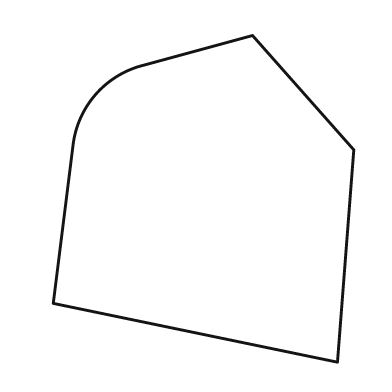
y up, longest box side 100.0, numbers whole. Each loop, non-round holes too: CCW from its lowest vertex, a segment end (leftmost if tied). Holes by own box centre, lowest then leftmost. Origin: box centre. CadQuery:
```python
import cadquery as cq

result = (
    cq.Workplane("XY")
    .moveTo(41.0, -50.0)
    .lineTo(46.0, 15.0)
    .lineTo(15.0, 50.0)
    .lineTo(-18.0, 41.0)
    .threePointArc((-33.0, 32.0), (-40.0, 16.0))
    .lineTo(-46.0, -32.0)
    .close()
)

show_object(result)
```